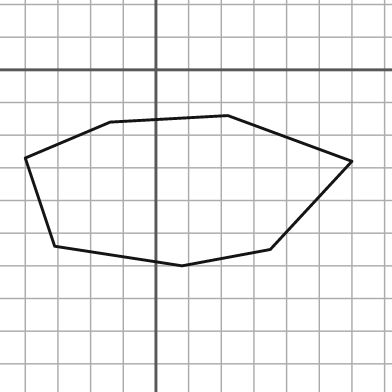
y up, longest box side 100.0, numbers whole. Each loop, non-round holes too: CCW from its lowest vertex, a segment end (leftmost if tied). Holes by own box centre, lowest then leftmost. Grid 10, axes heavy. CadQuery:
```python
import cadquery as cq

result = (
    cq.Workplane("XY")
    .moveTo(8.0, -60.0)
    .lineTo(35.0, -55.0)
    .lineTo(60.0, -28.0)
    .lineTo(22.0, -14.0)
    .lineTo(-14.0, -16.0)
    .lineTo(-40.0, -27.0)
    .lineTo(-31.0, -54.0)
    .close()
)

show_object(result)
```